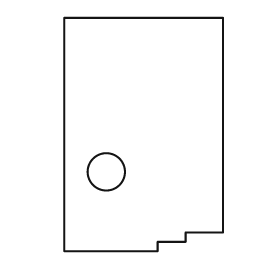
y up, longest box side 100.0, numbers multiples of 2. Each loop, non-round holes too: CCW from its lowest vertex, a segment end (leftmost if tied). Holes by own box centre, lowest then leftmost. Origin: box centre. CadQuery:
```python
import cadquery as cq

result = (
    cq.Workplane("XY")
    .moveTo(-34.0, -50.0)
    .lineTo(6.0, -50.0)
    .lineTo(6.0, -46.0)
    .lineTo(18.0, -46.0)
    .lineTo(18.0, -42.0)
    .lineTo(34.0, -42.0)
    .lineTo(34.0, 50.0)
    .lineTo(-34.0, 50.0)
    .close()
    .moveTo(-16.0, -16.0)
    .circle(8.0)
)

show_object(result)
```